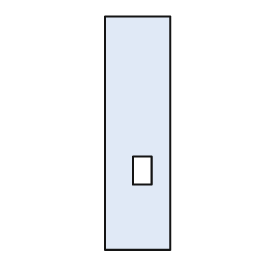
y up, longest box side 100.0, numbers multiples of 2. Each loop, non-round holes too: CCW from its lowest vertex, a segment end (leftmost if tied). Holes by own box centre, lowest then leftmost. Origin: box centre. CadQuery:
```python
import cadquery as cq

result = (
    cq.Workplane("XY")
    .moveTo(-14.0, -50.0)
    .lineTo(14.0, -50.0)
    .lineTo(14.0, 50.0)
    .lineTo(-14.0, 50.0)
    .close()
    .moveTo(-2.0, -22.0)
    .lineTo(6.0, -22.0)
    .lineTo(6.0, -10.0)
    .lineTo(-2.0, -10.0)
    .close()
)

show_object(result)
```